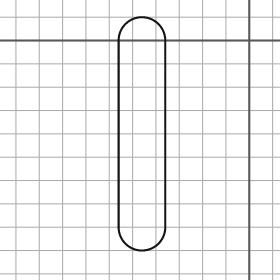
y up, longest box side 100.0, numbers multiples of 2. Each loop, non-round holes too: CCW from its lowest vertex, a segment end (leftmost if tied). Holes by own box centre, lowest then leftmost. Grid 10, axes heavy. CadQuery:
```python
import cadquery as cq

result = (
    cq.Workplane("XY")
    .moveTo(-56.0, -80.0)
    .threePointArc((-46.0, -90.0), (-36.0, -80.0))
    .lineTo(-36.0, 0.0)
    .threePointArc((-46.0, 10.0), (-56.0, 0.0))
    .close()
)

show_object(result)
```